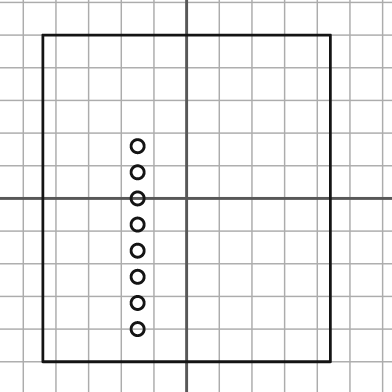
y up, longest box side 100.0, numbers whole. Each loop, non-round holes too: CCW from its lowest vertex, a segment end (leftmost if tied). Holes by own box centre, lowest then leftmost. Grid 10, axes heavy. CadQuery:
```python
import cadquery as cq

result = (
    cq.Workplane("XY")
    .moveTo(-44.0, -50.0)
    .lineTo(44.0, -50.0)
    .lineTo(44.0, 50.0)
    .lineTo(-44.0, 50.0)
    .close()
    .moveTo(-15.0, -40.0)
    .circle(2.0)
    .moveTo(-15.0, -32.0)
    .circle(2.0)
    .moveTo(-15.0, -24.0)
    .circle(2.0)
    .moveTo(-15.0, -16.0)
    .circle(2.0)
    .moveTo(-15.0, -8.0)
    .circle(2.0)
    .moveTo(-15.0, 0.0)
    .circle(2.0)
    .moveTo(-15.0, 8.0)
    .circle(2.0)
    .moveTo(-15.0, 16.0)
    .circle(2.0)
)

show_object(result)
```